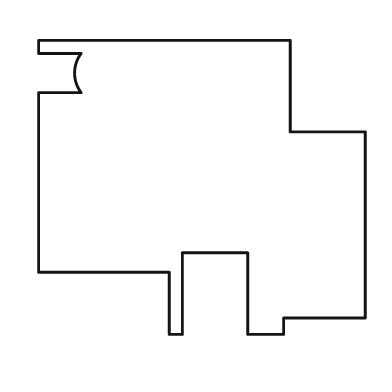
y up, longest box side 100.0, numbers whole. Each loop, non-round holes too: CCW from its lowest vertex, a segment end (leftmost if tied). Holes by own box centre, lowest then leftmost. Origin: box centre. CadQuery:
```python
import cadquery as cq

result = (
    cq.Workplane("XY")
    .moveTo(-10.0, -45.0)
    .lineTo(-6.0, -45.0)
    .lineTo(-6.0, -20.0)
    .lineTo(14.0, -20.0)
    .lineTo(14.0, -45.0)
    .lineTo(25.0, -45.0)
    .lineTo(25.0, -40.0)
    .lineTo(50.0, -40.0)
    .lineTo(50.0, 17.0)
    .lineTo(27.0, 17.0)
    .lineTo(27.0, 45.0)
    .lineTo(-50.0, 45.0)
    .lineTo(-50.0, 41.0)
    .lineTo(-37.0, 41.0)
    .threePointArc((-39.0, 35.0), (-37.0, 29.0))
    .lineTo(-50.0, 29.0)
    .lineTo(-50.0, -26.0)
    .lineTo(-10.0, -26.0)
    .close()
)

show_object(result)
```